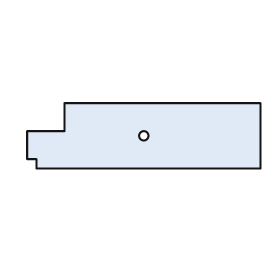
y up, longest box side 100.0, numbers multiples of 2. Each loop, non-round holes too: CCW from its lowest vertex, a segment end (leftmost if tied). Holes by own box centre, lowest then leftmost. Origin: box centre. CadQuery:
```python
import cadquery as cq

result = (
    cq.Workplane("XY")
    .moveTo(-46.0, -14.0)
    .lineTo(50.0, -14.0)
    .lineTo(50.0, 14.0)
    .lineTo(-34.0, 14.0)
    .lineTo(-34.0, 2.0)
    .lineTo(-50.0, 2.0)
    .lineTo(-50.0, -10.0)
    .lineTo(-46.0, -10.0)
    .close()
    .moveTo(0.0, 0.0)
    .circle(2.0)
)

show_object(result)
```